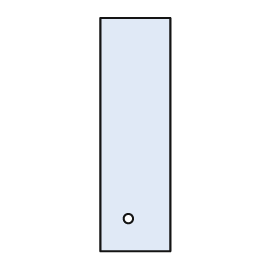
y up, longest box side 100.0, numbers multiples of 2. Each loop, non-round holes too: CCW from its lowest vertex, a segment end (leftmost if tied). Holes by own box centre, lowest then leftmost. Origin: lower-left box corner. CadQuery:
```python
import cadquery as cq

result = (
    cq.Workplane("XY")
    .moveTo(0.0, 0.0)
    .lineTo(30.0, 0.0)
    .lineTo(30.0, 100.0)
    .lineTo(0.0, 100.0)
    .close()
    .moveTo(12.0, 14.0)
    .circle(2.0)
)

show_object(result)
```